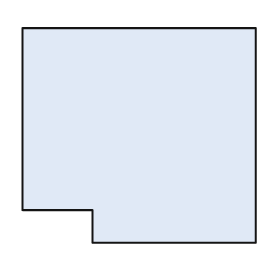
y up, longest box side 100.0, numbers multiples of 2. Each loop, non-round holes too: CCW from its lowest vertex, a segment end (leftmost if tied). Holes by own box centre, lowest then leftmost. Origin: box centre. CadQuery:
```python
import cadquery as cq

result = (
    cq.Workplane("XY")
    .moveTo(-20.0, -46.0)
    .lineTo(50.0, -46.0)
    .lineTo(50.0, 46.0)
    .lineTo(-50.0, 46.0)
    .lineTo(-50.0, -32.0)
    .lineTo(-20.0, -32.0)
    .close()
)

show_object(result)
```